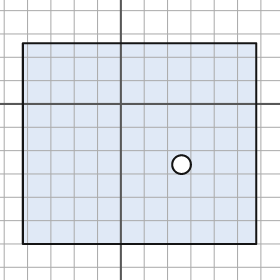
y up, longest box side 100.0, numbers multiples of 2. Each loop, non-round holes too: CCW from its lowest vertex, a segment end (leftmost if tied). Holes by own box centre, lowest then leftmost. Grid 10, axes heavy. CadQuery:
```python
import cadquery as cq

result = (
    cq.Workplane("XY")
    .moveTo(-42.0, -60.0)
    .lineTo(58.0, -60.0)
    .lineTo(58.0, 26.0)
    .lineTo(-42.0, 26.0)
    .close()
    .moveTo(26.0, -26.0)
    .circle(4.0)
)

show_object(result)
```